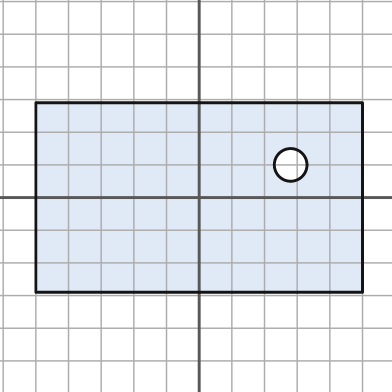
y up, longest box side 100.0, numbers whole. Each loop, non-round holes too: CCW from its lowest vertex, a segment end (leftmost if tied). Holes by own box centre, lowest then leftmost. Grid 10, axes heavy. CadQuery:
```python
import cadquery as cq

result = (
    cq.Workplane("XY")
    .moveTo(-50.0, -29.0)
    .lineTo(50.0, -29.0)
    .lineTo(50.0, 29.0)
    .lineTo(-50.0, 29.0)
    .close()
    .moveTo(28.0, 10.0)
    .circle(5.0)
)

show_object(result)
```